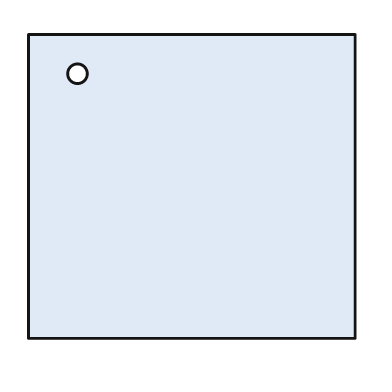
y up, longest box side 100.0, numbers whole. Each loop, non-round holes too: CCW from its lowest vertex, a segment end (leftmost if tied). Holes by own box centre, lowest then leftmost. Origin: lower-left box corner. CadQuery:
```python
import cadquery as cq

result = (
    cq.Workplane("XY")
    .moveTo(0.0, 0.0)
    .lineTo(100.0, 0.0)
    .lineTo(100.0, 93.0)
    .lineTo(0.0, 93.0)
    .close()
    .moveTo(15.0, 81.0)
    .circle(3.0)
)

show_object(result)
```